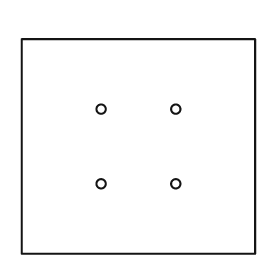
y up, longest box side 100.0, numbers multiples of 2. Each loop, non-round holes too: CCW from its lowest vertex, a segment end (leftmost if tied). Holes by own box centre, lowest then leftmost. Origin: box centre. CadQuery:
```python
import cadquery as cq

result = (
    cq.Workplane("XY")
    .moveTo(-50.0, -46.0)
    .lineTo(50.0, -46.0)
    .lineTo(50.0, 46.0)
    .lineTo(-50.0, 46.0)
    .close()
    .moveTo(-16.0, -16.0)
    .circle(2.0)
    .moveTo(16.0, -16.0)
    .circle(2.0)
    .moveTo(-16.0, 16.0)
    .circle(2.0)
    .moveTo(16.0, 16.0)
    .circle(2.0)
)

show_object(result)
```